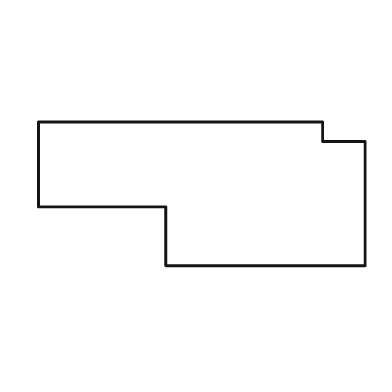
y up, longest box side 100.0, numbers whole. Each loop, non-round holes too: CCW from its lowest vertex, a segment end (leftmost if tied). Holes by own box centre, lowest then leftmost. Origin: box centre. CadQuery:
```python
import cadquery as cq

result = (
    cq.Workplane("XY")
    .moveTo(-11.0, -22.0)
    .lineTo(50.0, -22.0)
    .lineTo(50.0, 16.0)
    .lineTo(37.0, 16.0)
    .lineTo(37.0, 22.0)
    .lineTo(-50.0, 22.0)
    .lineTo(-50.0, -4.0)
    .lineTo(-11.0, -4.0)
    .close()
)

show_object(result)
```